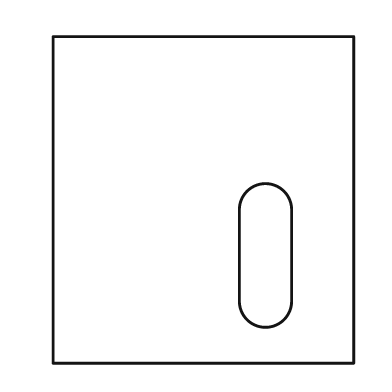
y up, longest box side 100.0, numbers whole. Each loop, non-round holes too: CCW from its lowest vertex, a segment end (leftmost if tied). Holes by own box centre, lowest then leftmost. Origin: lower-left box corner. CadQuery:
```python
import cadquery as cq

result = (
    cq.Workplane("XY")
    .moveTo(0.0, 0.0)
    .lineTo(92.0, 0.0)
    .lineTo(92.0, 100.0)
    .lineTo(0.0, 100.0)
    .close()
    .moveTo(57.0, 19.0)
    .threePointArc((65.0, 11.0), (73.0, 19.0))
    .lineTo(73.0, 47.0)
    .threePointArc((65.0, 55.0), (57.0, 47.0))
    .close()
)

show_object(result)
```